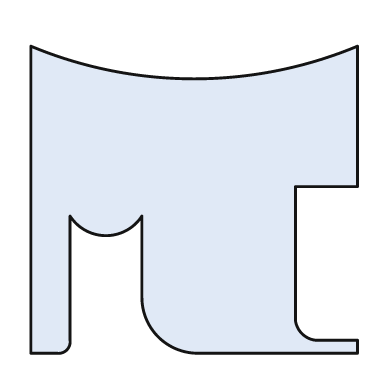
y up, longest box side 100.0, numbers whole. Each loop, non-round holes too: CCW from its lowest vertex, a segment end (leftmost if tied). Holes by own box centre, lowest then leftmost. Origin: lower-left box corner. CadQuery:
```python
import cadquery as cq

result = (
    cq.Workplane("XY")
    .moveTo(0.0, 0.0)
    .lineTo(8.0, 0.0)
    .threePointArc((11.0, 1.0), (12.0, 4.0))
    .lineTo(12.0, 42.0)
    .threePointArc((23.0, 36.0), (34.0, 42.0))
    .lineTo(34.0, 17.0)
    .threePointArc((39.0, 5.0), (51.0, 0.0))
    .lineTo(100.0, 0.0)
    .lineTo(100.0, 4.0)
    .lineTo(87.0, 4.0)
    .threePointArc((83.0, 6.0), (81.0, 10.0))
    .lineTo(81.0, 51.0)
    .lineTo(100.0, 51.0)
    .lineTo(100.0, 94.0)
    .threePointArc((50.0, 84.0), (0.0, 94.0))
    .close()
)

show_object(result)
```